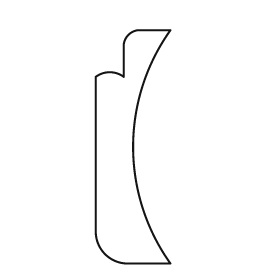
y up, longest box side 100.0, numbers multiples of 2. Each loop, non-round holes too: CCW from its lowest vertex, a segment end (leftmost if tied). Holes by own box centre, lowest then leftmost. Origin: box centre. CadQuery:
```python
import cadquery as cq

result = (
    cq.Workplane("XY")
    .moveTo(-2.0, -50.0)
    .lineTo(16.0, -50.0)
    .threePointArc((0.0, 0.0), (16.0, 50.0))
    .lineTo(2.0, 50.0)
    .threePointArc((-2.0, 48.0), (-4.0, 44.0))
    .lineTo(-4.0, 30.0)
    .threePointArc((-10.0, 32.0), (-16.0, 30.0))
    .lineTo(-16.0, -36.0)
    .threePointArc((-12.0, -46.0), (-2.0, -50.0))
    .close()
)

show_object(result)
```